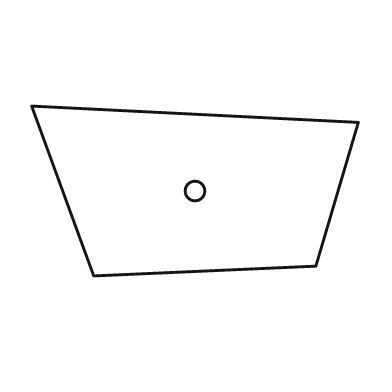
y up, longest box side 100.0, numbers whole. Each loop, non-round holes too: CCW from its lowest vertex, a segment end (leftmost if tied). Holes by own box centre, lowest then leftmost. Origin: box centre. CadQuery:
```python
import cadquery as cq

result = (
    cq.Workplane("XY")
    .moveTo(-31.0, -26.0)
    .lineTo(37.0, -23.0)
    .lineTo(50.0, 21.0)
    .lineTo(-50.0, 26.0)
    .close()
    .moveTo(0.0, 0.0)
    .circle(3.0)
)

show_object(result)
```